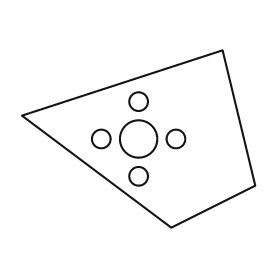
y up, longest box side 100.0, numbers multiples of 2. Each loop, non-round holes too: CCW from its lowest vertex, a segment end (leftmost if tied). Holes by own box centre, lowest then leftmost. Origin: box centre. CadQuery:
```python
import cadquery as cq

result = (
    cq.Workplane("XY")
    .moveTo(14.0, -38.0)
    .lineTo(50.0, -20.0)
    .lineTo(36.0, 38.0)
    .lineTo(-50.0, 10.0)
    .close()
    .moveTo(0.0, -16.0)
    .circle(4.0)
    .moveTo(-16.0, 0.0)
    .circle(4.0)
    .moveTo(0.0, 0.0)
    .circle(8.0)
    .moveTo(16.0, 0.0)
    .circle(4.0)
    .moveTo(0.0, 16.0)
    .circle(4.0)
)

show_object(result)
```